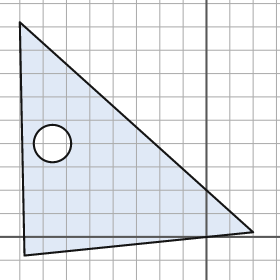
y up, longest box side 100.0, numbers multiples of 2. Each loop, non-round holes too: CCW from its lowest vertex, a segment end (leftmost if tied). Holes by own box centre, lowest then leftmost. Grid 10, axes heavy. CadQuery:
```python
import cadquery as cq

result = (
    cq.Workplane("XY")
    .moveTo(-78.0, -8.0)
    .lineTo(20.0, 2.0)
    .lineTo(-80.0, 92.0)
    .close()
    .moveTo(-66.0, 40.0)
    .circle(8.0)
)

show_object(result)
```